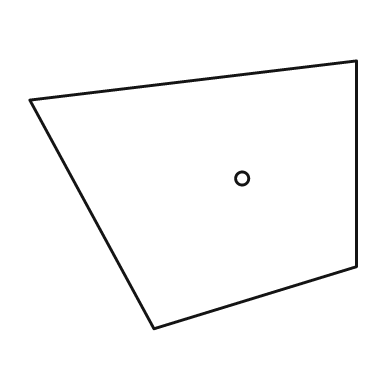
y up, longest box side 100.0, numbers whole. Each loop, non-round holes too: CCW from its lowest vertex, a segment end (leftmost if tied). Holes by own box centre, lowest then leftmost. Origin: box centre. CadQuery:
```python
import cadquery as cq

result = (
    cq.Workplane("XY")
    .moveTo(-12.0, -41.0)
    .lineTo(50.0, -22.0)
    .lineTo(50.0, 41.0)
    .lineTo(-50.0, 29.0)
    .close()
    .moveTo(15.0, 5.0)
    .circle(2.0)
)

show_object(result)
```